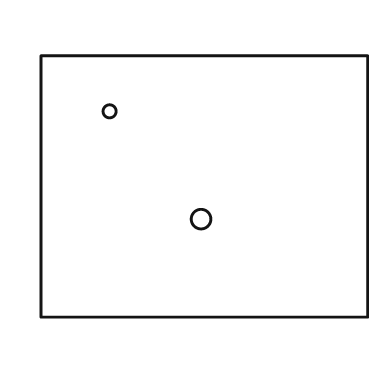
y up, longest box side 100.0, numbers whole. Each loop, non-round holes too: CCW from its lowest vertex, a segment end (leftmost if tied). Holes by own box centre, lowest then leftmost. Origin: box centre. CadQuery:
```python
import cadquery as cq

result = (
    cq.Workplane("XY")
    .moveTo(-50.0, -40.0)
    .lineTo(50.0, -40.0)
    .lineTo(50.0, 40.0)
    .lineTo(-50.0, 40.0)
    .close()
    .moveTo(-1.0, -10.0)
    .circle(3.0)
    .moveTo(-29.0, 23.0)
    .circle(2.0)
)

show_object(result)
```